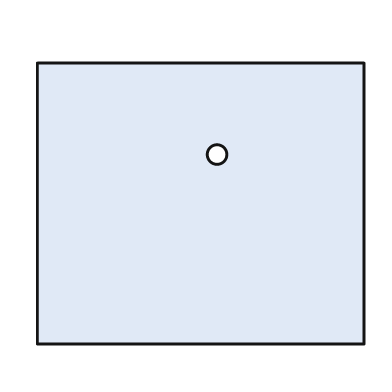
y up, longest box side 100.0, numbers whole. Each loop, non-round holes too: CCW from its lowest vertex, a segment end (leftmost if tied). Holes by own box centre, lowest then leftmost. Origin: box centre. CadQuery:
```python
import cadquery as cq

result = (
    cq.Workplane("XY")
    .moveTo(-50.0, -43.0)
    .lineTo(50.0, -43.0)
    .lineTo(50.0, 43.0)
    .lineTo(-50.0, 43.0)
    .close()
    .moveTo(5.0, 15.0)
    .circle(3.0)
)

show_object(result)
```